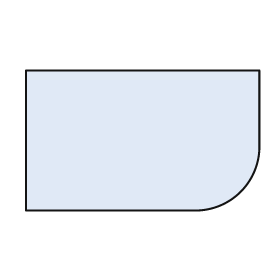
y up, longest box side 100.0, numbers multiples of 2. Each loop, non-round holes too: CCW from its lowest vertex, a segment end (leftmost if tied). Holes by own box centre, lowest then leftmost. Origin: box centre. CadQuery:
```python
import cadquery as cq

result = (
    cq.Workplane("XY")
    .moveTo(-50.0, -30.0)
    .lineTo(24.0, -30.0)
    .threePointArc((42.0, -22.0), (50.0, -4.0))
    .lineTo(50.0, 30.0)
    .lineTo(-50.0, 30.0)
    .close()
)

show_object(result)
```